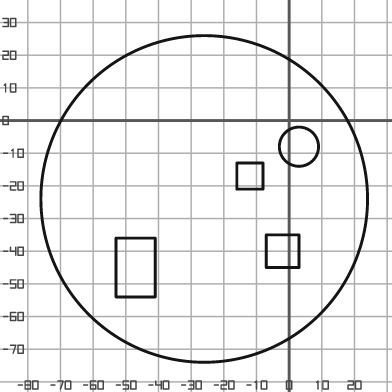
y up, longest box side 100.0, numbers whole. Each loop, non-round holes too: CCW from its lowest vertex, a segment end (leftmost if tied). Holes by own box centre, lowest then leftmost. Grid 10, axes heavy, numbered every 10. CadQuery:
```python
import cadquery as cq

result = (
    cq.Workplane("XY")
    .moveTo(-26.0, -24.0)
    .circle(50.0)
    .moveTo(-53.0, -54.0)
    .lineTo(-41.0, -54.0)
    .lineTo(-41.0, -36.0)
    .lineTo(-53.0, -36.0)
    .close()
    .moveTo(-7.0, -45.0)
    .lineTo(3.0, -45.0)
    .lineTo(3.0, -35.0)
    .lineTo(-7.0, -35.0)
    .close()
    .moveTo(-16.0, -21.0)
    .lineTo(-8.0, -21.0)
    .lineTo(-8.0, -13.0)
    .lineTo(-16.0, -13.0)
    .close()
    .moveTo(3.0, -8.0)
    .circle(6.0)
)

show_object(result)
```